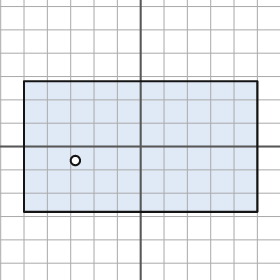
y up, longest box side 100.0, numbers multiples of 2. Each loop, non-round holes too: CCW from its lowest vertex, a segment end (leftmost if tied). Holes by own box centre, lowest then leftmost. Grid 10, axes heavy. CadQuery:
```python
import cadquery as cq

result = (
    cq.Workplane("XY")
    .moveTo(-50.0, -28.0)
    .lineTo(50.0, -28.0)
    .lineTo(50.0, 28.0)
    .lineTo(-50.0, 28.0)
    .close()
    .moveTo(-28.0, -6.0)
    .circle(2.0)
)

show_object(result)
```